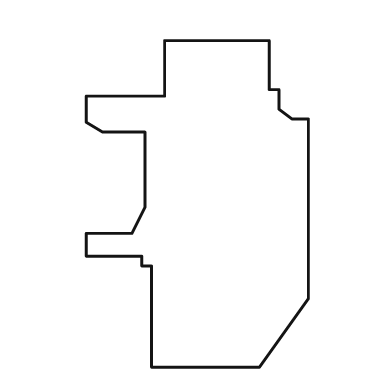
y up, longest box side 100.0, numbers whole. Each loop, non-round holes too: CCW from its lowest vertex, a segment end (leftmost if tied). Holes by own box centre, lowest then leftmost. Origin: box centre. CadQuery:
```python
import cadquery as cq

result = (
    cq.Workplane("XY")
    .moveTo(-14.0, -50.0)
    .lineTo(19.0, -50.0)
    .lineTo(34.0, -29.0)
    .lineTo(34.0, 26.0)
    .lineTo(29.0, 26.0)
    .lineTo(25.0, 29.0)
    .lineTo(25.0, 35.0)
    .lineTo(22.0, 35.0)
    .lineTo(22.0, 50.0)
    .lineTo(-10.0, 50.0)
    .lineTo(-10.0, 33.0)
    .lineTo(-34.0, 33.0)
    .lineTo(-34.0, 25.0)
    .lineTo(-29.0, 22.0)
    .lineTo(-16.0, 22.0)
    .lineTo(-16.0, -1.0)
    .lineTo(-20.0, -9.0)
    .lineTo(-34.0, -9.0)
    .lineTo(-34.0, -16.0)
    .lineTo(-17.0, -16.0)
    .lineTo(-17.0, -19.0)
    .lineTo(-14.0, -19.0)
    .close()
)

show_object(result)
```